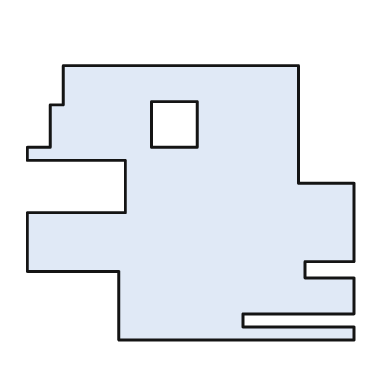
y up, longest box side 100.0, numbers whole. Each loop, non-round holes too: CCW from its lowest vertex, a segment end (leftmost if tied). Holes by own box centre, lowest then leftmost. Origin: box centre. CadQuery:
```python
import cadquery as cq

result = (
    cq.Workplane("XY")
    .moveTo(-22.0, -42.0)
    .lineTo(50.0, -42.0)
    .lineTo(50.0, -38.0)
    .lineTo(16.0, -38.0)
    .lineTo(16.0, -34.0)
    .lineTo(50.0, -34.0)
    .lineTo(50.0, -23.0)
    .lineTo(35.0, -23.0)
    .lineTo(35.0, -18.0)
    .lineTo(50.0, -18.0)
    .lineTo(50.0, 6.0)
    .lineTo(33.0, 6.0)
    .lineTo(33.0, 42.0)
    .lineTo(-39.0, 42.0)
    .lineTo(-39.0, 30.0)
    .lineTo(-43.0, 30.0)
    .lineTo(-43.0, 17.0)
    .lineTo(-50.0, 17.0)
    .lineTo(-50.0, 13.0)
    .lineTo(-20.0, 13.0)
    .lineTo(-20.0, -3.0)
    .lineTo(-50.0, -3.0)
    .lineTo(-50.0, -21.0)
    .lineTo(-22.0, -21.0)
    .close()
    .moveTo(-12.0, 17.0)
    .lineTo(2.0, 17.0)
    .lineTo(2.0, 31.0)
    .lineTo(-12.0, 31.0)
    .close()
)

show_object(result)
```